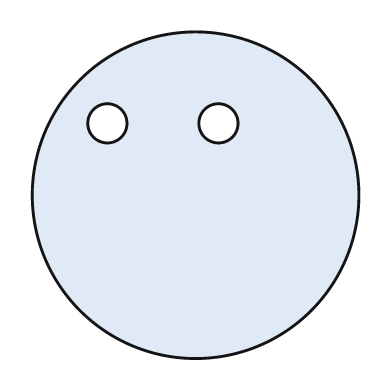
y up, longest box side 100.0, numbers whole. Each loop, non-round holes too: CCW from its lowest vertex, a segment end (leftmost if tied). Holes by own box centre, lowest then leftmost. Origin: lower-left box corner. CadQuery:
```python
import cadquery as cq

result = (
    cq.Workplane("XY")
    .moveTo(50.0, 50.0)
    .circle(50.0)
    .moveTo(23.0, 72.0)
    .circle(6.0)
    .moveTo(57.0, 72.0)
    .circle(6.0)
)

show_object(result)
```